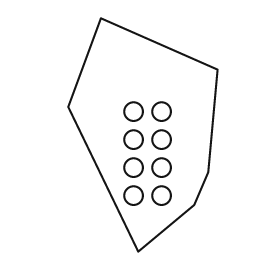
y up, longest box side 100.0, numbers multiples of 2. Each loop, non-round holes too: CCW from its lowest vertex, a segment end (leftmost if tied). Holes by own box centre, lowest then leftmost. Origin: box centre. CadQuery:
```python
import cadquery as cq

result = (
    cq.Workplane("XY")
    .moveTo(-2.0, -50.0)
    .lineTo(22.0, -30.0)
    .lineTo(28.0, -16.0)
    .lineTo(32.0, 28.0)
    .lineTo(-18.0, 50.0)
    .lineTo(-32.0, 12.0)
    .close()
    .moveTo(-4.0, -26.0)
    .circle(4.0)
    .moveTo(8.0, -26.0)
    .circle(4.0)
    .moveTo(-4.0, -14.0)
    .circle(4.0)
    .moveTo(8.0, -14.0)
    .circle(4.0)
    .moveTo(-4.0, -2.0)
    .circle(4.0)
    .moveTo(8.0, -2.0)
    .circle(4.0)
    .moveTo(-4.0, 10.0)
    .circle(4.0)
    .moveTo(8.0, 10.0)
    .circle(4.0)
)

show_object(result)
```